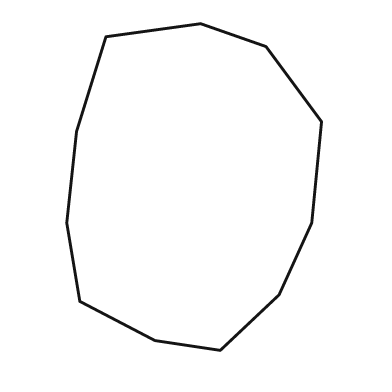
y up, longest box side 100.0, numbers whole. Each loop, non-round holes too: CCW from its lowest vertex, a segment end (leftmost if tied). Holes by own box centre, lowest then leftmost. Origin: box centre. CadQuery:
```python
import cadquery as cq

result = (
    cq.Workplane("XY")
    .moveTo(8.0, -50.0)
    .lineTo(26.0, -33.0)
    .lineTo(36.0, -11.0)
    .lineTo(39.0, 20.0)
    .lineTo(22.0, 43.0)
    .lineTo(2.0, 50.0)
    .lineTo(-27.0, 46.0)
    .lineTo(-36.0, 17.0)
    .lineTo(-39.0, -11.0)
    .lineTo(-35.0, -35.0)
    .lineTo(-12.0, -47.0)
    .close()
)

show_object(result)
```